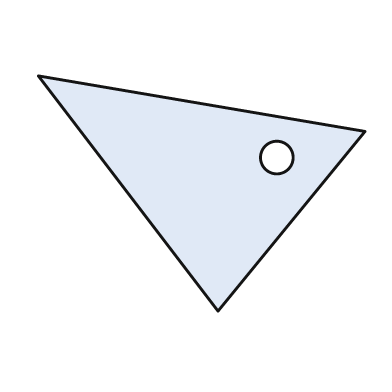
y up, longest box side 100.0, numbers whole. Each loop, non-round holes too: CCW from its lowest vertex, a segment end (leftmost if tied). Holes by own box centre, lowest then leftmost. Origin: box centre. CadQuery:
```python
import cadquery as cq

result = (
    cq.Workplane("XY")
    .moveTo(5.0, -36.0)
    .lineTo(50.0, 19.0)
    .lineTo(-50.0, 36.0)
    .close()
    .moveTo(23.0, 11.0)
    .circle(5.0)
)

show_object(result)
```